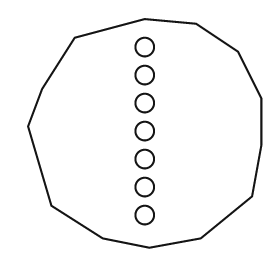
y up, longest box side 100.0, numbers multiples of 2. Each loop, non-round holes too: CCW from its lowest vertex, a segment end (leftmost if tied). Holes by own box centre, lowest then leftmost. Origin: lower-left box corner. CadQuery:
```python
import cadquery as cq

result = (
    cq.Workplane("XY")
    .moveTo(52.0, 0.0)
    .lineTo(74.0, 4.0)
    .lineTo(96.0, 22.0)
    .lineTo(100.0, 44.0)
    .lineTo(100.0, 64.0)
    .lineTo(90.0, 84.0)
    .lineTo(72.0, 96.0)
    .lineTo(50.0, 98.0)
    .lineTo(20.0, 90.0)
    .lineTo(6.0, 68.0)
    .lineTo(0.0, 52.0)
    .lineTo(10.0, 18.0)
    .lineTo(32.0, 4.0)
    .close()
    .moveTo(50.0, 14.0)
    .circle(4.0)
    .moveTo(50.0, 26.0)
    .circle(4.0)
    .moveTo(50.0, 38.0)
    .circle(4.0)
    .moveTo(50.0, 50.0)
    .circle(4.0)
    .moveTo(50.0, 62.0)
    .circle(4.0)
    .moveTo(50.0, 74.0)
    .circle(4.0)
    .moveTo(50.0, 86.0)
    .circle(4.0)
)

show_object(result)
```